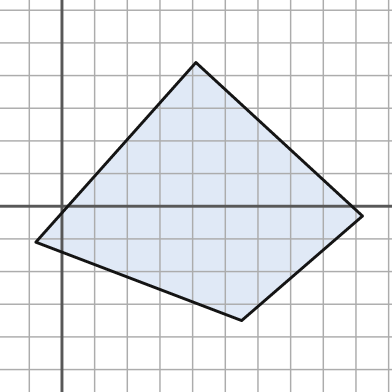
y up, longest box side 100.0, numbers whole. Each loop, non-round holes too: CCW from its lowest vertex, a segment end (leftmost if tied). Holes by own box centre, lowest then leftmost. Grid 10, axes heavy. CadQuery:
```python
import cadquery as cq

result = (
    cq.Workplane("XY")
    .moveTo(55.0, -35.0)
    .lineTo(92.0, -3.0)
    .lineTo(41.0, 44.0)
    .lineTo(-8.0, -11.0)
    .close()
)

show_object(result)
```